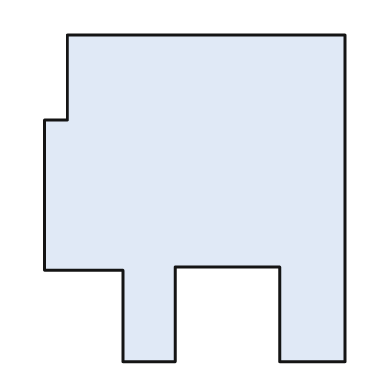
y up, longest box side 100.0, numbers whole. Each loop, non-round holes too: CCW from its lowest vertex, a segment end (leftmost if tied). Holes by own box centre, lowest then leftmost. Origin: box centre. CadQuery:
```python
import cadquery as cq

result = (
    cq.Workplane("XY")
    .moveTo(-22.0, -50.0)
    .lineTo(-6.0, -50.0)
    .lineTo(-6.0, -21.0)
    .lineTo(26.0, -21.0)
    .lineTo(26.0, -50.0)
    .lineTo(46.0, -50.0)
    .lineTo(46.0, 50.0)
    .lineTo(-39.0, 50.0)
    .lineTo(-39.0, 24.0)
    .lineTo(-46.0, 24.0)
    .lineTo(-46.0, -22.0)
    .lineTo(-22.0, -22.0)
    .close()
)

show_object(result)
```